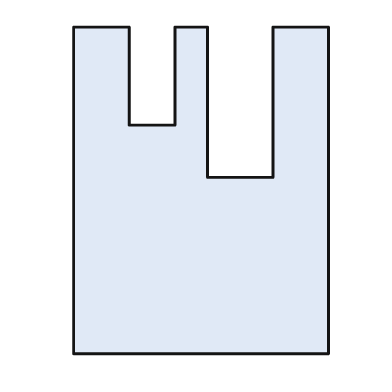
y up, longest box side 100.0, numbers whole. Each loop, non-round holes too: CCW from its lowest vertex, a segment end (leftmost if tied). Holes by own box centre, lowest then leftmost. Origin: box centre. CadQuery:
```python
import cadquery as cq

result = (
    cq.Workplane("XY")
    .moveTo(-39.0, -50.0)
    .lineTo(39.0, -50.0)
    .lineTo(39.0, 50.0)
    .lineTo(22.0, 50.0)
    .lineTo(22.0, 4.0)
    .lineTo(2.0, 4.0)
    .lineTo(2.0, 50.0)
    .lineTo(-8.0, 50.0)
    .lineTo(-8.0, 20.0)
    .lineTo(-22.0, 20.0)
    .lineTo(-22.0, 50.0)
    .lineTo(-39.0, 50.0)
    .close()
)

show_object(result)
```